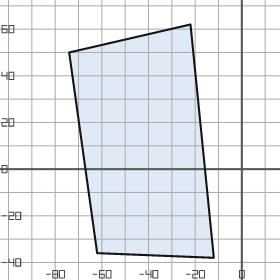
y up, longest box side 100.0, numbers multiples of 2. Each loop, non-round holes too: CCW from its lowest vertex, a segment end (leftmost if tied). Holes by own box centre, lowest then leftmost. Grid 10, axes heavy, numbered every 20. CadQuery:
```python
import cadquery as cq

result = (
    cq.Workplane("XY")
    .moveTo(-12.0, -38.0)
    .lineTo(-22.0, 62.0)
    .lineTo(-74.0, 50.0)
    .lineTo(-62.0, -36.0)
    .close()
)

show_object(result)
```